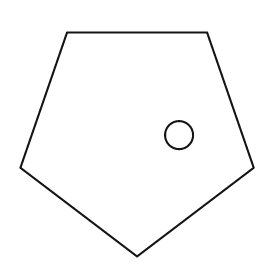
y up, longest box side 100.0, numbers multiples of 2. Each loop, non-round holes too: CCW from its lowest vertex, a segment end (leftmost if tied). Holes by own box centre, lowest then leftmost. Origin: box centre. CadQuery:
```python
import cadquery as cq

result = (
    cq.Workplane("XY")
    .moveTo(0.0, -48.0)
    .lineTo(50.0, -10.0)
    .lineTo(30.0, 48.0)
    .lineTo(-30.0, 48.0)
    .lineTo(-50.0, -10.0)
    .close()
    .moveTo(18.0, 4.0)
    .circle(6.0)
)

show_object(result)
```